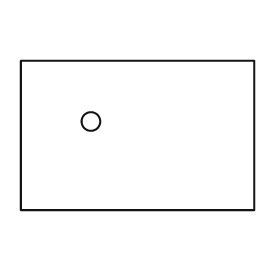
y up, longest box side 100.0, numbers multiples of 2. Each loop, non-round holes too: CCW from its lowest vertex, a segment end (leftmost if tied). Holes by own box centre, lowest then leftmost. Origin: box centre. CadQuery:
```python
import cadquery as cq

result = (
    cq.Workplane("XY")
    .moveTo(-50.0, -32.0)
    .lineTo(50.0, -32.0)
    .lineTo(50.0, 32.0)
    .lineTo(-50.0, 32.0)
    .close()
    .moveTo(-20.0, 6.0)
    .circle(4.0)
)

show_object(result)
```